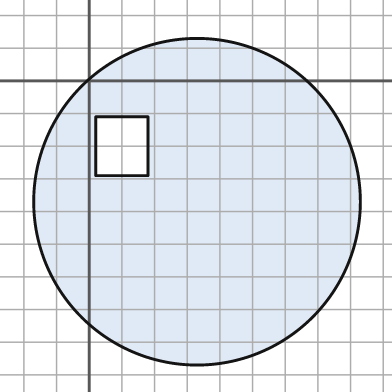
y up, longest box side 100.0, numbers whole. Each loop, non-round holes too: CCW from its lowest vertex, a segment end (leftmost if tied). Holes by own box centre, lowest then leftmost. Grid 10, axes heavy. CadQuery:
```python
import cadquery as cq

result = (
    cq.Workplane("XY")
    .moveTo(33.0, -37.0)
    .circle(50.0)
    .moveTo(2.0, -29.0)
    .lineTo(18.0, -29.0)
    .lineTo(18.0, -11.0)
    .lineTo(2.0, -11.0)
    .close()
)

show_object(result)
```